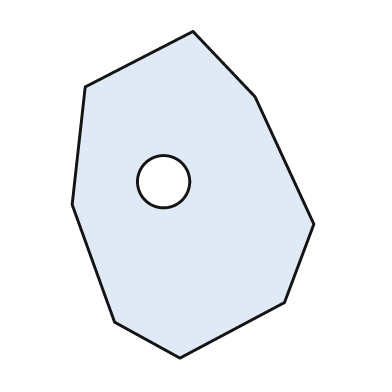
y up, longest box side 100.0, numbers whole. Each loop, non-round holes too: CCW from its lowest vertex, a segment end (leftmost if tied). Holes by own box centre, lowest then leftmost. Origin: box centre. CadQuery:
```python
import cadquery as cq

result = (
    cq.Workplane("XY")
    .moveTo(-4.0, -50.0)
    .lineTo(28.0, -33.0)
    .lineTo(37.0, -9.0)
    .lineTo(19.0, 30.0)
    .lineTo(0.0, 50.0)
    .lineTo(-33.0, 33.0)
    .lineTo(-37.0, -3.0)
    .lineTo(-24.0, -39.0)
    .close()
    .moveTo(-9.0, 4.0)
    .circle(8.0)
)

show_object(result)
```